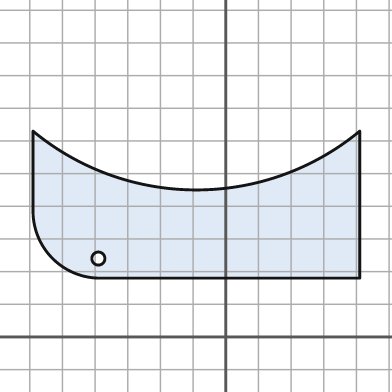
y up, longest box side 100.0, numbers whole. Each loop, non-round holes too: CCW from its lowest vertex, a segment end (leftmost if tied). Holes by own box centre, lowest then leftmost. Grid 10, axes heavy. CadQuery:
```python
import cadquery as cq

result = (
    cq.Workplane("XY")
    .moveTo(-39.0, 18.0)
    .lineTo(41.0, 18.0)
    .lineTo(41.0, 63.0)
    .threePointArc((-9.0, 45.0), (-59.0, 63.0))
    .lineTo(-59.0, 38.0)
    .threePointArc((-53.0, 24.0), (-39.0, 18.0))
    .close()
    .moveTo(-39.0, 24.0)
    .circle(2.0)
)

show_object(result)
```